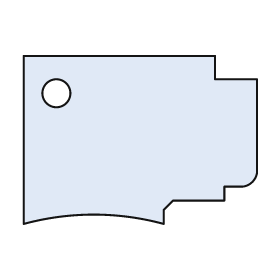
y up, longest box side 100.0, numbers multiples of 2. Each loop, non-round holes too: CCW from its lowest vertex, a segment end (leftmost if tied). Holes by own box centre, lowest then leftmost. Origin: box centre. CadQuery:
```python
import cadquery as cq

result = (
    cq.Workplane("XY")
    .moveTo(-50.0, -36.0)
    .threePointArc((-20.0, -32.0), (10.0, -36.0))
    .lineTo(10.0, -30.0)
    .lineTo(14.0, -26.0)
    .lineTo(36.0, -26.0)
    .lineTo(36.0, -20.0)
    .lineTo(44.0, -20.0)
    .threePointArc((48.0, -18.0), (50.0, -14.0))
    .lineTo(50.0, 26.0)
    .lineTo(32.0, 26.0)
    .lineTo(32.0, 36.0)
    .lineTo(-50.0, 36.0)
    .close()
    .moveTo(-36.0, 20.0)
    .circle(6.0)
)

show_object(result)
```